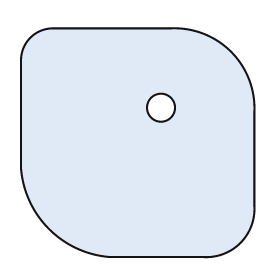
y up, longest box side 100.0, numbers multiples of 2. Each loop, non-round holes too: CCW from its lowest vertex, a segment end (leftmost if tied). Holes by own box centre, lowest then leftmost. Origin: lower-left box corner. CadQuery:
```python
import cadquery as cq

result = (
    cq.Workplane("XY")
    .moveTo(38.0, 0.0)
    .lineTo(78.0, 0.0)
    .threePointArc((94.0, 6.0), (100.0, 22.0))
    .lineTo(100.0, 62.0)
    .threePointArc((90.0, 88.0), (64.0, 98.0))
    .lineTo(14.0, 98.0)
    .threePointArc((4.0, 94.0), (0.0, 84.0))
    .lineTo(0.0, 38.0)
    .threePointArc((12.0, 12.0), (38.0, 0.0))
    .close()
    .moveTo(60.0, 64.0)
    .circle(6.0)
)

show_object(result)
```